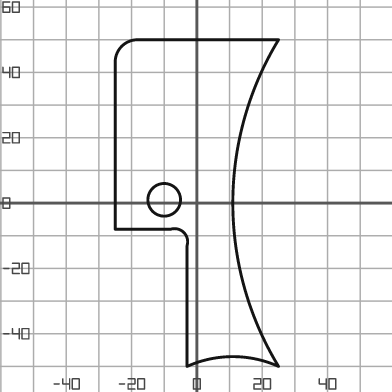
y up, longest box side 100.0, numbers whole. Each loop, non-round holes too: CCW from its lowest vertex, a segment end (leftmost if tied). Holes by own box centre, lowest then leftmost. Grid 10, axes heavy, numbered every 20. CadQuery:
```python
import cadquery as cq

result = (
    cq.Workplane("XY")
    .moveTo(-3.0, -50.0)
    .threePointArc((11.0, -47.0), (25.0, -50.0))
    .threePointArc((11.0, 0.0), (25.0, 50.0))
    .lineTo(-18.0, 50.0)
    .threePointArc((-23.0, 48.0), (-25.0, 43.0))
    .lineTo(-25.0, -8.0)
    .lineTo(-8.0, -8.0)
    .threePointArc((-4.0, -9.0), (-3.0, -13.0))
    .close()
    .moveTo(-10.0, 1.0)
    .circle(5.0)
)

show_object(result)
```